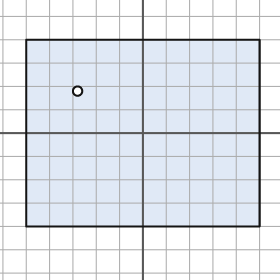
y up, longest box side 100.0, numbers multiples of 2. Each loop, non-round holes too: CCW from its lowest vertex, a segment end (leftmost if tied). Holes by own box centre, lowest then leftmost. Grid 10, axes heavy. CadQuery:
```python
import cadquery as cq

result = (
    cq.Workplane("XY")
    .moveTo(-50.0, -40.0)
    .lineTo(50.0, -40.0)
    .lineTo(50.0, 40.0)
    .lineTo(-50.0, 40.0)
    .close()
    .moveTo(-28.0, 18.0)
    .circle(2.0)
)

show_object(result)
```